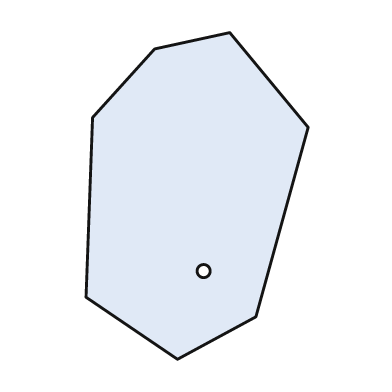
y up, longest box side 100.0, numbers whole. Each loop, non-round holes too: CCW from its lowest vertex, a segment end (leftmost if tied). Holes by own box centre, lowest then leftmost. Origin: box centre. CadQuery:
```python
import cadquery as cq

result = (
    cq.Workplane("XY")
    .moveTo(-6.0, -50.0)
    .lineTo(18.0, -37.0)
    .lineTo(34.0, 21.0)
    .lineTo(10.0, 50.0)
    .lineTo(-13.0, 45.0)
    .lineTo(-32.0, 24.0)
    .lineTo(-34.0, -31.0)
    .close()
    .moveTo(2.0, -23.0)
    .circle(2.0)
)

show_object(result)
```